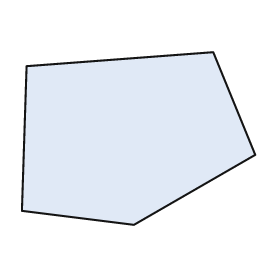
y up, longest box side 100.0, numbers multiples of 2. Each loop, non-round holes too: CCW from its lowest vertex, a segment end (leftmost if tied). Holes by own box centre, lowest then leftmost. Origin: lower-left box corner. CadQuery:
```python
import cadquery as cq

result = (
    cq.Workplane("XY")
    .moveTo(48.0, 0.0)
    .lineTo(100.0, 30.0)
    .lineTo(82.0, 74.0)
    .lineTo(2.0, 68.0)
    .lineTo(0.0, 6.0)
    .close()
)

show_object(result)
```